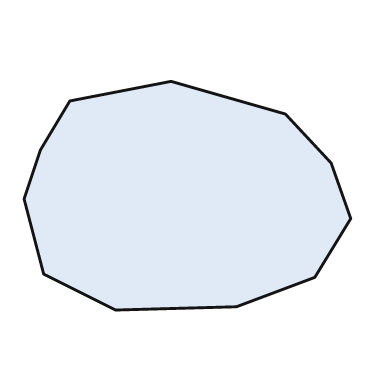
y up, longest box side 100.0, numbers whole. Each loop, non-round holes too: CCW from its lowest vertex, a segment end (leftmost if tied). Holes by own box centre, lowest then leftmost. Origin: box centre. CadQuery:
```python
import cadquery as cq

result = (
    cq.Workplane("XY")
    .moveTo(-22.0, -35.0)
    .lineTo(15.0, -34.0)
    .lineTo(39.0, -25.0)
    .lineTo(50.0, -7.0)
    .lineTo(44.0, 10.0)
    .lineTo(30.0, 25.0)
    .lineTo(-5.0, 35.0)
    .lineTo(-36.0, 29.0)
    .lineTo(-45.0, 14.0)
    .lineTo(-50.0, -1.0)
    .lineTo(-44.0, -24.0)
    .close()
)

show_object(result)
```